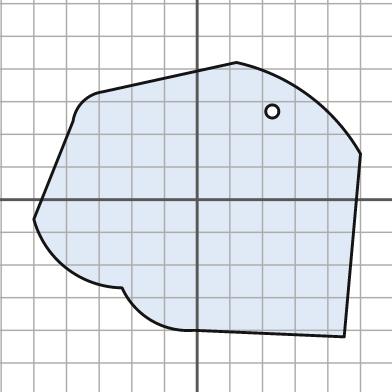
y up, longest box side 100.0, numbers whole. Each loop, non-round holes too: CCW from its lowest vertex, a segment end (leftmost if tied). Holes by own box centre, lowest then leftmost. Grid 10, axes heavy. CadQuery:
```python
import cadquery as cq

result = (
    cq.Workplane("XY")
    .moveTo(45.0, -42.0)
    .lineTo(50.0, 14.0)
    .threePointArc((34.0, 32.0), (12.0, 42.0))
    .lineTo(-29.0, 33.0)
    .threePointArc((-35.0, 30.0), (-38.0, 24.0))
    .lineTo(-50.0, -6.0)
    .threePointArc((-40.0, -21.0), (-23.0, -27.0))
    .threePointArc((-14.0, -37.0), (-1.0, -40.0))
    .close()
    .moveTo(23.0, 27.0)
    .circle(2.0)
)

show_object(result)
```